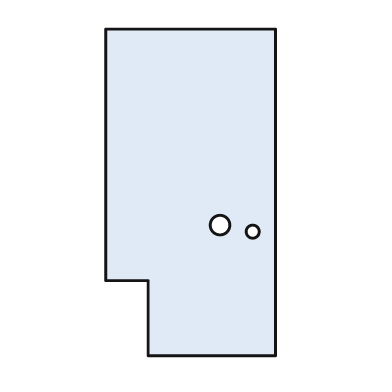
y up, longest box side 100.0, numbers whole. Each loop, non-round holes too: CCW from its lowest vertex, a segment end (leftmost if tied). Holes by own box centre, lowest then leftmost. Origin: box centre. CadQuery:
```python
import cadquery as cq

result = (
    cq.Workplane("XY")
    .moveTo(-13.0, -50.0)
    .lineTo(26.0, -50.0)
    .lineTo(26.0, 50.0)
    .lineTo(-26.0, 50.0)
    .lineTo(-26.0, -27.0)
    .lineTo(-13.0, -27.0)
    .close()
    .moveTo(19.0, -12.0)
    .circle(2.0)
    .moveTo(9.0, -10.0)
    .circle(3.0)
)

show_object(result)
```